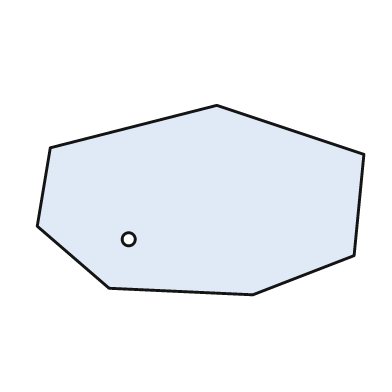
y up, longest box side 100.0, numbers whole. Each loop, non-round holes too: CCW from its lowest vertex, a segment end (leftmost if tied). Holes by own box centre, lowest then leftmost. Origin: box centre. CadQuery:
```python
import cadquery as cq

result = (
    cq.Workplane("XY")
    .moveTo(16.0, -29.0)
    .lineTo(47.0, -17.0)
    .lineTo(50.0, 14.0)
    .lineTo(5.0, 29.0)
    .lineTo(-46.0, 16.0)
    .lineTo(-50.0, -8.0)
    .lineTo(-28.0, -27.0)
    .close()
    .moveTo(-22.0, -12.0)
    .circle(2.0)
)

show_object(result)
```